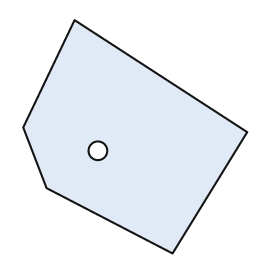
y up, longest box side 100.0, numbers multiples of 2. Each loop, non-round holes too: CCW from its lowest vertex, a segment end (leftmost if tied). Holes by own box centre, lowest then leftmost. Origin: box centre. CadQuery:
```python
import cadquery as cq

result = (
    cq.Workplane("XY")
    .moveTo(16.0, -50.0)
    .lineTo(48.0, 2.0)
    .lineTo(-26.0, 50.0)
    .lineTo(-48.0, 4.0)
    .lineTo(-38.0, -22.0)
    .close()
    .moveTo(-16.0, -6.0)
    .circle(4.0)
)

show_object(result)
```